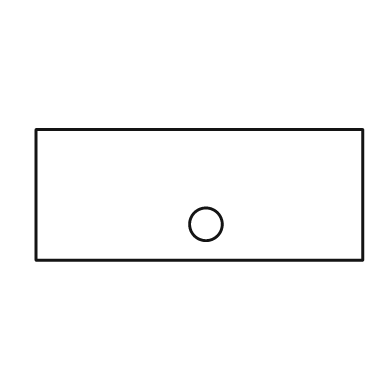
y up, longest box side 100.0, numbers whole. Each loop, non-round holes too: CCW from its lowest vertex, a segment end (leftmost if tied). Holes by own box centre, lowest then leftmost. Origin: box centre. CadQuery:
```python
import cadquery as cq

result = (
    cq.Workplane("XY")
    .moveTo(-50.0, -20.0)
    .lineTo(50.0, -20.0)
    .lineTo(50.0, 20.0)
    .lineTo(-50.0, 20.0)
    .close()
    .moveTo(2.0, -9.0)
    .circle(5.0)
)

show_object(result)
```